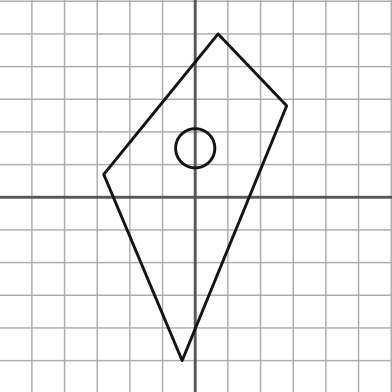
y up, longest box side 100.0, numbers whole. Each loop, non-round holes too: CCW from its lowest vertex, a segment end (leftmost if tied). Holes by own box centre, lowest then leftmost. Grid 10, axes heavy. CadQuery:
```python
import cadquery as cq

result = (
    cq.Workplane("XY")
    .moveTo(-4.0, -50.0)
    .lineTo(28.0, 28.0)
    .lineTo(7.0, 50.0)
    .lineTo(-28.0, 7.0)
    .close()
    .moveTo(0.0, 15.0)
    .circle(6.0)
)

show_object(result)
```